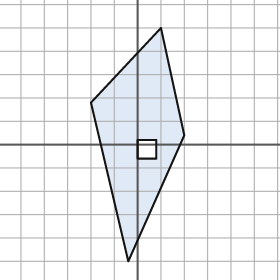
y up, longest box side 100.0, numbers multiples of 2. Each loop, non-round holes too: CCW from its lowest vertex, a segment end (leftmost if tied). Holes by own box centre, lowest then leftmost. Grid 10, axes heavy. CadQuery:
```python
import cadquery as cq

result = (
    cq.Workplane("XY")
    .moveTo(-4.0, -50.0)
    .lineTo(20.0, 4.0)
    .lineTo(10.0, 50.0)
    .lineTo(-20.0, 18.0)
    .close()
    .moveTo(0.0, -6.0)
    .lineTo(8.0, -6.0)
    .lineTo(8.0, 2.0)
    .lineTo(0.0, 2.0)
    .close()
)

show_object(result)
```